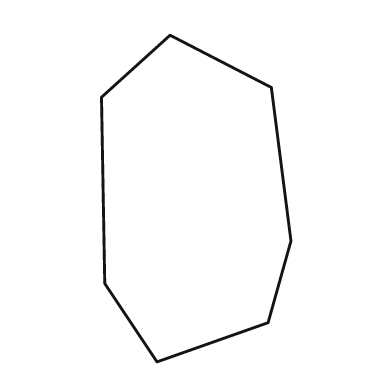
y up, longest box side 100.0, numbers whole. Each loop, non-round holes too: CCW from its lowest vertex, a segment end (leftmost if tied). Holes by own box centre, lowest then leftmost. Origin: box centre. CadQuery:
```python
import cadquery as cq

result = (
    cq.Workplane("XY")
    .moveTo(-12.0, -50.0)
    .lineTo(22.0, -38.0)
    .lineTo(29.0, -13.0)
    .lineTo(23.0, 34.0)
    .lineTo(-8.0, 50.0)
    .lineTo(-29.0, 31.0)
    .lineTo(-28.0, -26.0)
    .close()
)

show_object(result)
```